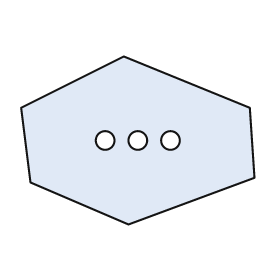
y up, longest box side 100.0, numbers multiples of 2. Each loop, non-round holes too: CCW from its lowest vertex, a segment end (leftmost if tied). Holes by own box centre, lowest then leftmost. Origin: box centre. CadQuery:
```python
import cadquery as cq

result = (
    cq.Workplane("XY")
    .moveTo(-4.0, -36.0)
    .lineTo(50.0, -16.0)
    .lineTo(48.0, 14.0)
    .lineTo(-6.0, 36.0)
    .lineTo(-50.0, 14.0)
    .lineTo(-46.0, -18.0)
    .close()
    .moveTo(-14.0, 0.0)
    .circle(4.0)
    .moveTo(0.0, 0.0)
    .circle(4.0)
    .moveTo(14.0, 0.0)
    .circle(4.0)
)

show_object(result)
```